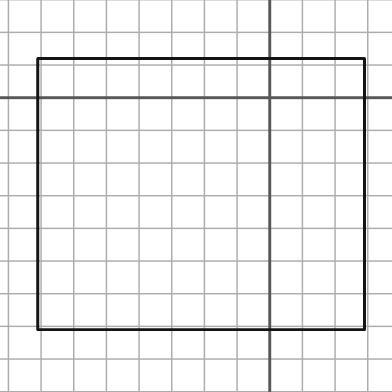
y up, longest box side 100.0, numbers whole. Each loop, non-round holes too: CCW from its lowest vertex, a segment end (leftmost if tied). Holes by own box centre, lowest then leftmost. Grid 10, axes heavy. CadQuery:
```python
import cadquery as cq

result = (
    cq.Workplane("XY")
    .moveTo(-71.0, -71.0)
    .lineTo(29.0, -71.0)
    .lineTo(29.0, 12.0)
    .lineTo(-71.0, 12.0)
    .close()
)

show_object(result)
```